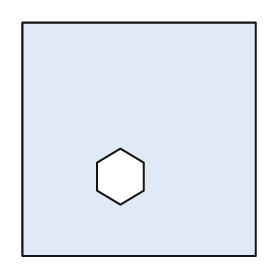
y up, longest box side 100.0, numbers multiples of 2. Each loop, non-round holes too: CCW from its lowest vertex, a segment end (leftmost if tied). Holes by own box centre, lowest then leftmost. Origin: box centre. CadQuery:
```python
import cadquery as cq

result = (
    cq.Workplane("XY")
    .moveTo(-50.0, -50.0)
    .lineTo(50.0, -50.0)
    .lineTo(50.0, 50.0)
    .lineTo(-50.0, 50.0)
    .close()
    .moveTo(-8.0, -28.0)
    .lineTo(2.0, -22.0)
    .lineTo(2.0, -10.0)
    .lineTo(-8.0, -4.0)
    .lineTo(-18.0, -10.0)
    .lineTo(-18.0, -22.0)
    .close()
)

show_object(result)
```